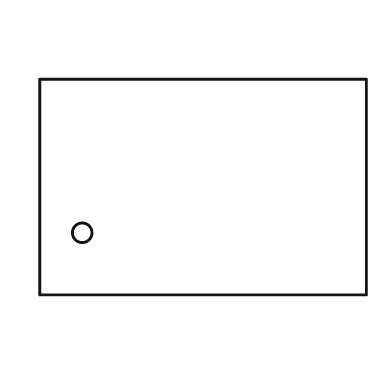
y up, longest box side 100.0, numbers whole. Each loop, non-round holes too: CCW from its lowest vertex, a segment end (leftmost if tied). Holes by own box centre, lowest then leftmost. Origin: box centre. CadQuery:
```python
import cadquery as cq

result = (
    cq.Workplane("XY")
    .moveTo(-50.0, -33.0)
    .lineTo(50.0, -33.0)
    .lineTo(50.0, 33.0)
    .lineTo(-50.0, 33.0)
    .close()
    .moveTo(-37.0, -14.0)
    .circle(3.0)
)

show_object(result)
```